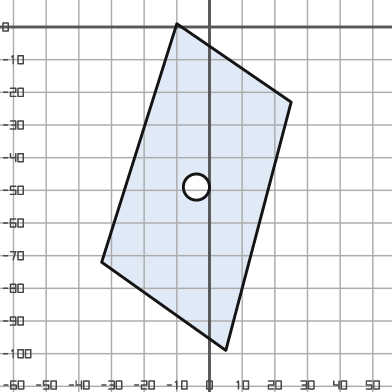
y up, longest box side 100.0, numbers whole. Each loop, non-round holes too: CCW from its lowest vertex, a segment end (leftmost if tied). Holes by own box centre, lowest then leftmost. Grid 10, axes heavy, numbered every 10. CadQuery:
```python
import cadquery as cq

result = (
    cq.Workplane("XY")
    .moveTo(5.0, -99.0)
    .lineTo(25.0, -23.0)
    .lineTo(-10.0, 1.0)
    .lineTo(-33.0, -72.0)
    .close()
    .moveTo(-4.0, -49.0)
    .circle(4.0)
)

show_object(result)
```